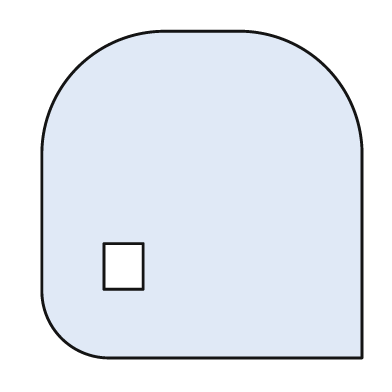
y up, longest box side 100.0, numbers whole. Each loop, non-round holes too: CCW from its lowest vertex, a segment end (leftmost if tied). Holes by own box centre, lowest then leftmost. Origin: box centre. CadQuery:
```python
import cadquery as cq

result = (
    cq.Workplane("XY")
    .moveTo(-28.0, -50.0)
    .lineTo(49.0, -50.0)
    .lineTo(49.0, 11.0)
    .threePointArc((38.0, 39.0), (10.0, 50.0))
    .lineTo(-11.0, 50.0)
    .threePointArc((-38.0, 39.0), (-49.0, 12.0))
    .lineTo(-49.0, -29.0)
    .threePointArc((-43.0, -44.0), (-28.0, -50.0))
    .close()
    .moveTo(-30.0, -29.0)
    .lineTo(-18.0, -29.0)
    .lineTo(-18.0, -15.0)
    .lineTo(-30.0, -15.0)
    .close()
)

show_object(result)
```